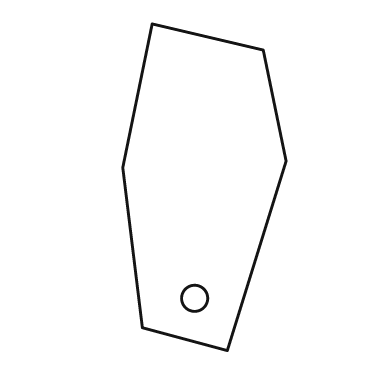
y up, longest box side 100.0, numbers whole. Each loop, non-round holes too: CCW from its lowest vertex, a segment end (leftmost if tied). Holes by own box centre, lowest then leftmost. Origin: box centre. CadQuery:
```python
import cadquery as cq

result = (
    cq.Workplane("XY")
    .moveTo(7.0, -50.0)
    .lineTo(25.0, 8.0)
    .lineTo(18.0, 42.0)
    .lineTo(-16.0, 50.0)
    .lineTo(-25.0, 6.0)
    .lineTo(-19.0, -43.0)
    .close()
    .moveTo(-3.0, -34.0)
    .circle(4.0)
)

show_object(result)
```